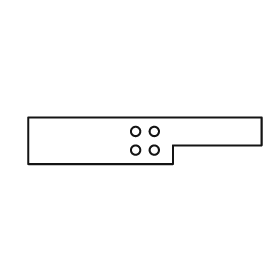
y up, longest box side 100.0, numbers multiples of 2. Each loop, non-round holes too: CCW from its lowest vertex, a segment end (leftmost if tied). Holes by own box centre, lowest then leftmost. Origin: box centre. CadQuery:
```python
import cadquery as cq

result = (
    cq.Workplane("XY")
    .moveTo(-50.0, -10.0)
    .lineTo(12.0, -10.0)
    .lineTo(12.0, -2.0)
    .lineTo(50.0, -2.0)
    .lineTo(50.0, 10.0)
    .lineTo(-50.0, 10.0)
    .close()
    .moveTo(-4.0, -4.0)
    .circle(2.0)
    .moveTo(4.0, -4.0)
    .circle(2.0)
    .moveTo(-4.0, 4.0)
    .circle(2.0)
    .moveTo(4.0, 4.0)
    .circle(2.0)
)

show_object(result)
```